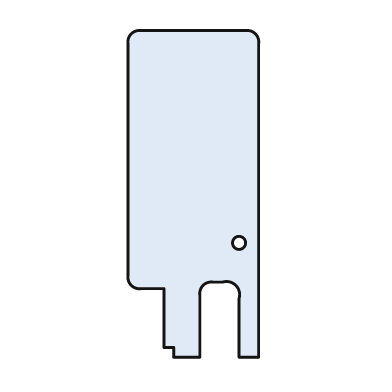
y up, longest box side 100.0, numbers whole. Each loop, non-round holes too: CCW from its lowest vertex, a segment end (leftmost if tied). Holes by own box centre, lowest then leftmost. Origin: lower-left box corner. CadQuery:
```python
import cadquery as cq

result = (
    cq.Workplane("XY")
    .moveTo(14.0, 0.0)
    .lineTo(22.0, 0.0)
    .lineTo(22.0, 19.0)
    .threePointArc((23.0, 22.0), (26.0, 23.0))
    .lineTo(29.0, 23.0)
    .threePointArc((33.0, 22.0), (34.0, 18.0))
    .lineTo(34.0, 0.0)
    .lineTo(40.0, 0.0)
    .lineTo(40.0, 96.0)
    .threePointArc((39.0, 99.0), (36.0, 100.0))
    .lineTo(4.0, 100.0)
    .threePointArc((1.0, 99.0), (0.0, 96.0))
    .lineTo(0.0, 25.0)
    .threePointArc((1.0, 22.0), (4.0, 21.0))
    .lineTo(11.0, 21.0)
    .lineTo(11.0, 3.0)
    .lineTo(14.0, 3.0)
    .close()
    .moveTo(34.0, 35.0)
    .circle(2.0)
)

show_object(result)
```